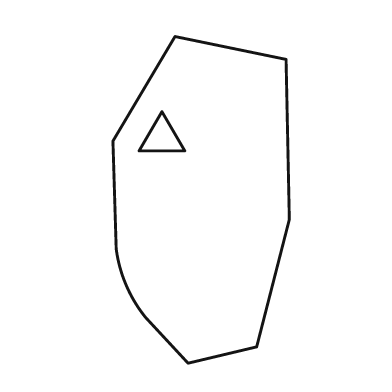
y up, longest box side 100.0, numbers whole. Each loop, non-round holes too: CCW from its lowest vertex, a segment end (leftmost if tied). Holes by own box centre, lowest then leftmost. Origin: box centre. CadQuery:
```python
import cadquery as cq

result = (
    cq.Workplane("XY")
    .moveTo(-4.0, -50.0)
    .lineTo(17.0, -45.0)
    .lineTo(27.0, -6.0)
    .lineTo(26.0, 43.0)
    .lineTo(-8.0, 50.0)
    .lineTo(-27.0, 18.0)
    .lineTo(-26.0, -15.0)
    .threePointArc((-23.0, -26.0), (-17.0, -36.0))
    .close()
    .moveTo(-19.0, 15.0)
    .lineTo(-5.0, 15.0)
    .lineTo(-12.0, 27.0)
    .close()
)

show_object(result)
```